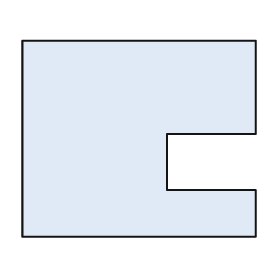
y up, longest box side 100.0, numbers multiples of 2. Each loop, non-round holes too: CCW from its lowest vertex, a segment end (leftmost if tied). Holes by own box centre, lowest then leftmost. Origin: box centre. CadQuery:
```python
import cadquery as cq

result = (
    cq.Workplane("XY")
    .moveTo(-50.0, -42.0)
    .lineTo(50.0, -42.0)
    .lineTo(50.0, -22.0)
    .lineTo(12.0, -22.0)
    .lineTo(12.0, 2.0)
    .lineTo(50.0, 2.0)
    .lineTo(50.0, 42.0)
    .lineTo(-50.0, 42.0)
    .close()
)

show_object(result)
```